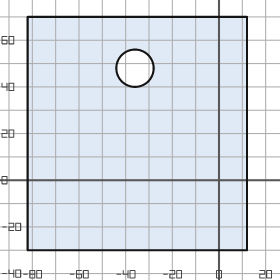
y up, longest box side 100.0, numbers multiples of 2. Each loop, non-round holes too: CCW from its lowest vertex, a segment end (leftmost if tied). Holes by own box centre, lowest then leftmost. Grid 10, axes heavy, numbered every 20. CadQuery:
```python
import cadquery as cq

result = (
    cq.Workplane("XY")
    .moveTo(-82.0, -30.0)
    .lineTo(12.0, -30.0)
    .lineTo(12.0, 70.0)
    .lineTo(-82.0, 70.0)
    .close()
    .moveTo(-36.0, 48.0)
    .circle(8.0)
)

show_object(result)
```